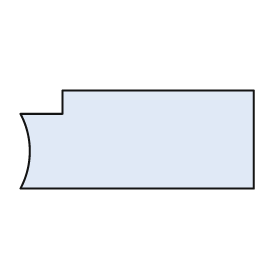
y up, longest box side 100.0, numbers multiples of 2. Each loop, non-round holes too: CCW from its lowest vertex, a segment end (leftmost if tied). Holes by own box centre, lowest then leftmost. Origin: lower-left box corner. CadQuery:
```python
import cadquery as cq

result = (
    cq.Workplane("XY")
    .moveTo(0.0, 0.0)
    .lineTo(100.0, 0.0)
    .lineTo(100.0, 42.0)
    .lineTo(18.0, 42.0)
    .lineTo(18.0, 32.0)
    .lineTo(0.0, 32.0)
    .threePointArc((4.0, 16.0), (0.0, 0.0))
    .close()
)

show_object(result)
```